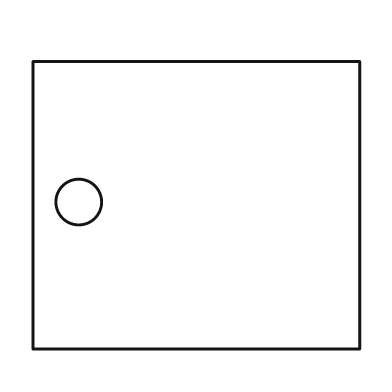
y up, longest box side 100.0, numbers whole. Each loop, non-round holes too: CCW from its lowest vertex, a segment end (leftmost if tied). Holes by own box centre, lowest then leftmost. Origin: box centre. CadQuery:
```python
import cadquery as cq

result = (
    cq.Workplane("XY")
    .moveTo(-50.0, -44.0)
    .lineTo(50.0, -44.0)
    .lineTo(50.0, 44.0)
    .lineTo(-50.0, 44.0)
    .close()
    .moveTo(-36.0, 1.0)
    .circle(7.0)
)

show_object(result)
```